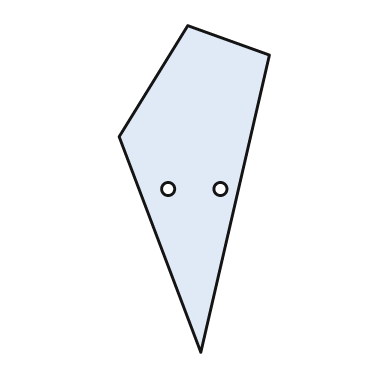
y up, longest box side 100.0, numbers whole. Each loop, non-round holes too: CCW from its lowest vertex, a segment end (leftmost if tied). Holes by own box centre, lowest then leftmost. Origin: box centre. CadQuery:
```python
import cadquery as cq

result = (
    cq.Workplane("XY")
    .moveTo(2.0, -50.0)
    .lineTo(23.0, 41.0)
    .lineTo(-2.0, 50.0)
    .lineTo(-23.0, 16.0)
    .close()
    .moveTo(-8.0, 0.0)
    .circle(2.0)
    .moveTo(8.0, 0.0)
    .circle(2.0)
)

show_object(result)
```